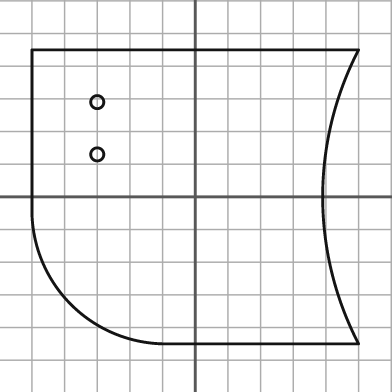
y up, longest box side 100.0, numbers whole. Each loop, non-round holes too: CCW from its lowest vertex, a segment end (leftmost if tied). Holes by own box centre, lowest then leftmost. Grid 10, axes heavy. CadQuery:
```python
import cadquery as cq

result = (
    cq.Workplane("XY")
    .moveTo(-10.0, -45.0)
    .lineTo(50.0, -45.0)
    .threePointArc((39.0, 0.0), (50.0, 45.0))
    .lineTo(-50.0, 45.0)
    .lineTo(-50.0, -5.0)
    .threePointArc((-38.0, -33.0), (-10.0, -45.0))
    .close()
    .moveTo(-30.0, 13.0)
    .circle(2.0)
    .moveTo(-30.0, 29.0)
    .circle(2.0)
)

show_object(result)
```